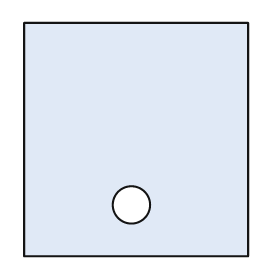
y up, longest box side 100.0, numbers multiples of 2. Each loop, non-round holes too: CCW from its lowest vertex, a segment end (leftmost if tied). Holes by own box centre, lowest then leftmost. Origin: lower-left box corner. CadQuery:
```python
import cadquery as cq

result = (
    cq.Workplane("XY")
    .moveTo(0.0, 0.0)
    .lineTo(96.0, 0.0)
    .lineTo(96.0, 100.0)
    .lineTo(0.0, 100.0)
    .close()
    .moveTo(46.0, 22.0)
    .circle(8.0)
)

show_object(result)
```